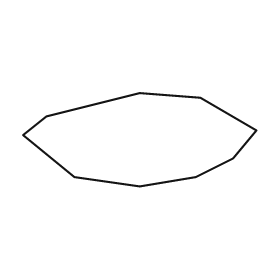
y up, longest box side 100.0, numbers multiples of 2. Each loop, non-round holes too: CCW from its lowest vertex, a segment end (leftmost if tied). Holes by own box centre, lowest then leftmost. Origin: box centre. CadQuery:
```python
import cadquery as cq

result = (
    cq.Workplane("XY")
    .moveTo(0.0, -20.0)
    .lineTo(24.0, -16.0)
    .lineTo(40.0, -8.0)
    .lineTo(50.0, 4.0)
    .lineTo(26.0, 18.0)
    .lineTo(0.0, 20.0)
    .lineTo(-40.0, 10.0)
    .lineTo(-50.0, 2.0)
    .lineTo(-28.0, -16.0)
    .close()
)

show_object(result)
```